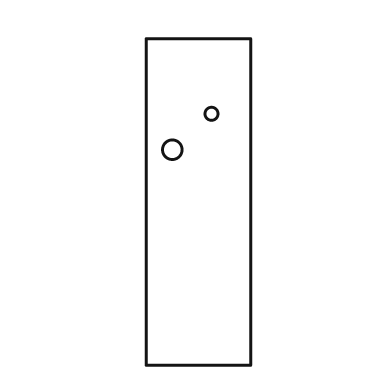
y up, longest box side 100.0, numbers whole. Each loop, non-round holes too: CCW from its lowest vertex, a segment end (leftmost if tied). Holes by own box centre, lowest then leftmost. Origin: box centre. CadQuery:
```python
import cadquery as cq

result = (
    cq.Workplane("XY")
    .moveTo(-16.0, -50.0)
    .lineTo(16.0, -50.0)
    .lineTo(16.0, 50.0)
    .lineTo(-16.0, 50.0)
    .close()
    .moveTo(-8.0, 16.0)
    .circle(3.0)
    .moveTo(4.0, 27.0)
    .circle(2.0)
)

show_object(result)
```